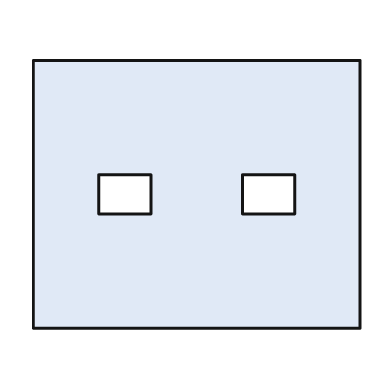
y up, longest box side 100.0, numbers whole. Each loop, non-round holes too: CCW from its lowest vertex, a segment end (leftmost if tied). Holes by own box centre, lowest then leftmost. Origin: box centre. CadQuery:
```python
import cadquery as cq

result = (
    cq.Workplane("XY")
    .moveTo(-50.0, -41.0)
    .lineTo(50.0, -41.0)
    .lineTo(50.0, 41.0)
    .lineTo(-50.0, 41.0)
    .close()
    .moveTo(-30.0, -6.0)
    .lineTo(-14.0, -6.0)
    .lineTo(-14.0, 6.0)
    .lineTo(-30.0, 6.0)
    .close()
    .moveTo(14.0, -6.0)
    .lineTo(30.0, -6.0)
    .lineTo(30.0, 6.0)
    .lineTo(14.0, 6.0)
    .close()
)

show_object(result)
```